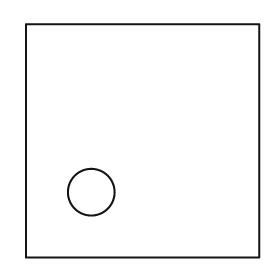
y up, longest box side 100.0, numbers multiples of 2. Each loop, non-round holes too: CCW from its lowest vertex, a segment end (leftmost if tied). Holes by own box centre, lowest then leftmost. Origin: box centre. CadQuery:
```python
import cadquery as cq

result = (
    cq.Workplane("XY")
    .moveTo(-50.0, -50.0)
    .lineTo(50.0, -50.0)
    .lineTo(50.0, 50.0)
    .lineTo(-50.0, 50.0)
    .close()
    .moveTo(-22.0, -22.0)
    .circle(10.0)
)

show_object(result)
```